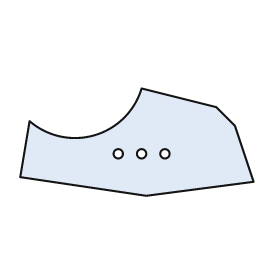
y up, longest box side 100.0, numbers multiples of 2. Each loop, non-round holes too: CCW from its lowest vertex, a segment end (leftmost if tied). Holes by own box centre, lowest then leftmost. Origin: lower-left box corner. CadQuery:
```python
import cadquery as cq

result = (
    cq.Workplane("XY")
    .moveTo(54.0, 0.0)
    .lineTo(100.0, 6.0)
    .lineTo(92.0, 30.0)
    .lineTo(84.0, 38.0)
    .lineTo(52.0, 46.0)
    .threePointArc((32.0, 26.0), (4.0, 32.0))
    .lineTo(0.0, 8.0)
    .close()
    .moveTo(42.0, 18.0)
    .circle(2.0)
    .moveTo(52.0, 18.0)
    .circle(2.0)
    .moveTo(62.0, 18.0)
    .circle(2.0)
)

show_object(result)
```